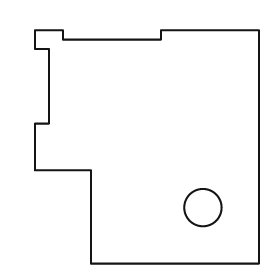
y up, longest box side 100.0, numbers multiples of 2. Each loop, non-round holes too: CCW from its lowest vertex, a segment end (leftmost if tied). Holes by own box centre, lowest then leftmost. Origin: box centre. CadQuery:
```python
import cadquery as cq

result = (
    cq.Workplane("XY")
    .moveTo(-24.0, -50.0)
    .lineTo(48.0, -50.0)
    .lineTo(48.0, 50.0)
    .lineTo(6.0, 50.0)
    .lineTo(6.0, 46.0)
    .lineTo(-36.0, 46.0)
    .lineTo(-36.0, 50.0)
    .lineTo(-48.0, 50.0)
    .lineTo(-48.0, 42.0)
    .lineTo(-42.0, 42.0)
    .lineTo(-42.0, 10.0)
    .lineTo(-48.0, 10.0)
    .lineTo(-48.0, -10.0)
    .lineTo(-24.0, -10.0)
    .close()
    .moveTo(24.0, -26.0)
    .circle(8.0)
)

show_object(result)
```